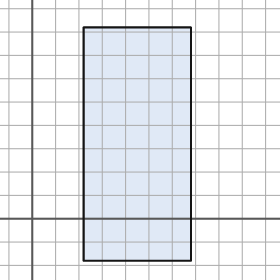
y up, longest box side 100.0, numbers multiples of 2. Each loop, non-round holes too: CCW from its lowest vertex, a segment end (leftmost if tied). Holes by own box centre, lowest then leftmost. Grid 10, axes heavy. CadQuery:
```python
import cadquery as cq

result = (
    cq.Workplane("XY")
    .moveTo(22.0, -18.0)
    .lineTo(68.0, -18.0)
    .lineTo(68.0, 82.0)
    .lineTo(22.0, 82.0)
    .close()
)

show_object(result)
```